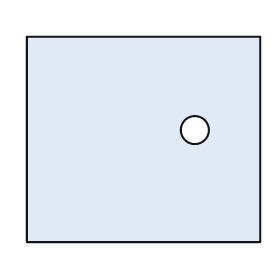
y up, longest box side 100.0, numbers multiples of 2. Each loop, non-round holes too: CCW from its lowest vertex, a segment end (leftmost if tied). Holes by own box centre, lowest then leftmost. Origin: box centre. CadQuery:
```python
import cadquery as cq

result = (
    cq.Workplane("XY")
    .moveTo(-50.0, -44.0)
    .lineTo(50.0, -44.0)
    .lineTo(50.0, 44.0)
    .lineTo(-50.0, 44.0)
    .close()
    .moveTo(22.0, 4.0)
    .circle(6.0)
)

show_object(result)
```